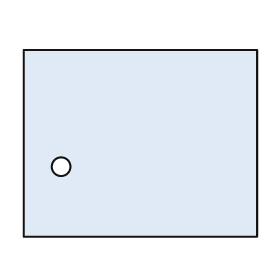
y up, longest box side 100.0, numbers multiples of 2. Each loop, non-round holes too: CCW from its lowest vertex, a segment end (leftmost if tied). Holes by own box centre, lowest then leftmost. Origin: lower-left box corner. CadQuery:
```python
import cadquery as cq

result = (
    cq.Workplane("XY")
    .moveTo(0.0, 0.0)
    .lineTo(100.0, 0.0)
    .lineTo(100.0, 80.0)
    .lineTo(0.0, 80.0)
    .close()
    .moveTo(16.0, 30.0)
    .circle(4.0)
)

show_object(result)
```